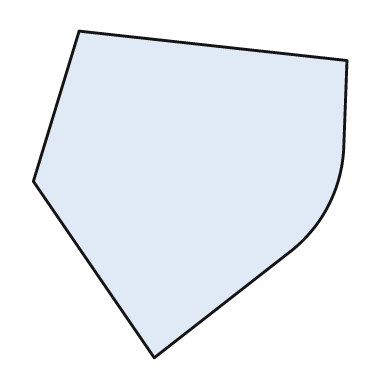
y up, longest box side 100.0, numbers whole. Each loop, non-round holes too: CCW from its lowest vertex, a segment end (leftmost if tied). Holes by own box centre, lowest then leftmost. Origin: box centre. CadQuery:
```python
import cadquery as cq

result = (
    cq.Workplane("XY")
    .moveTo(-11.0, -50.0)
    .lineTo(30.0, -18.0)
    .threePointArc((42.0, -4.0), (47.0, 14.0))
    .lineTo(48.0, 41.0)
    .lineTo(-34.0, 50.0)
    .lineTo(-48.0, 4.0)
    .close()
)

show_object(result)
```